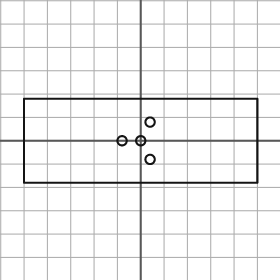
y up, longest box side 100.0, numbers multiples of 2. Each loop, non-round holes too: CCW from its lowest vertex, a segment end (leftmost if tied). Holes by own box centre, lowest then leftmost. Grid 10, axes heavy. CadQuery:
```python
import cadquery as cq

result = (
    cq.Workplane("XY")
    .moveTo(-50.0, -18.0)
    .lineTo(50.0, -18.0)
    .lineTo(50.0, 18.0)
    .lineTo(-50.0, 18.0)
    .close()
    .moveTo(4.0, -8.0)
    .circle(2.0)
    .moveTo(-8.0, 0.0)
    .circle(2.0)
    .moveTo(0.0, 0.0)
    .circle(2.0)
    .moveTo(4.0, 8.0)
    .circle(2.0)
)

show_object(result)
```